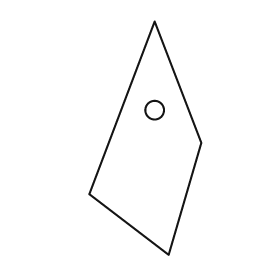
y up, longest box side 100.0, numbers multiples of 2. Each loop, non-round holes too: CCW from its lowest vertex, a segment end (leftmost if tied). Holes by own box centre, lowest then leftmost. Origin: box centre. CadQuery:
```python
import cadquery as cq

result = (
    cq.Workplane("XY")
    .moveTo(10.0, -50.0)
    .lineTo(24.0, -2.0)
    .lineTo(4.0, 50.0)
    .lineTo(-24.0, -24.0)
    .close()
    .moveTo(4.0, 12.0)
    .circle(4.0)
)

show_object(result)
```